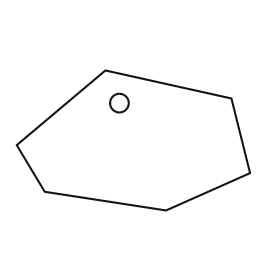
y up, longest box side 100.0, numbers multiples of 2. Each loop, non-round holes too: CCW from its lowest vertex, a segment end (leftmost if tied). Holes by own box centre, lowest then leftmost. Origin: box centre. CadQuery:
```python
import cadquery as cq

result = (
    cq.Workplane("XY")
    .moveTo(14.0, -30.0)
    .lineTo(50.0, -14.0)
    .lineTo(42.0, 18.0)
    .lineTo(-12.0, 30.0)
    .lineTo(-50.0, -2.0)
    .lineTo(-38.0, -22.0)
    .close()
    .moveTo(-6.0, 16.0)
    .circle(4.0)
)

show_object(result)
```